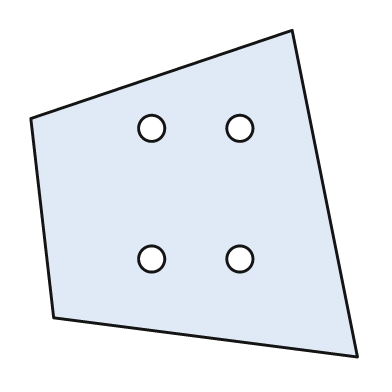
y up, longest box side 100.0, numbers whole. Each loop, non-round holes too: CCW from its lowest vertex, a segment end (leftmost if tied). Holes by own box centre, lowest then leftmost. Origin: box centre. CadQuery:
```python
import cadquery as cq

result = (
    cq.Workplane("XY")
    .moveTo(50.0, -50.0)
    .lineTo(30.0, 50.0)
    .lineTo(-50.0, 23.0)
    .lineTo(-43.0, -38.0)
    .close()
    .moveTo(-13.0, -20.0)
    .circle(4.0)
    .moveTo(14.0, -20.0)
    .circle(4.0)
    .moveTo(-13.0, 20.0)
    .circle(4.0)
    .moveTo(14.0, 20.0)
    .circle(4.0)
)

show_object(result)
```